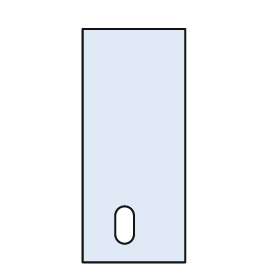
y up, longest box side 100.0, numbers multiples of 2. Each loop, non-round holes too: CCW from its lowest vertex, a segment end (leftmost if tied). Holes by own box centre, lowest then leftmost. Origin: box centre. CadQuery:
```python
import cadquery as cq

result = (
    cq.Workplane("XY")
    .moveTo(-22.0, -50.0)
    .lineTo(22.0, -50.0)
    .lineTo(22.0, 50.0)
    .lineTo(-22.0, 50.0)
    .close()
    .moveTo(-8.0, -38.0)
    .threePointArc((-4.0, -42.0), (0.0, -38.0))
    .lineTo(0.0, -30.0)
    .threePointArc((-4.0, -26.0), (-8.0, -30.0))
    .close()
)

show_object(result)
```